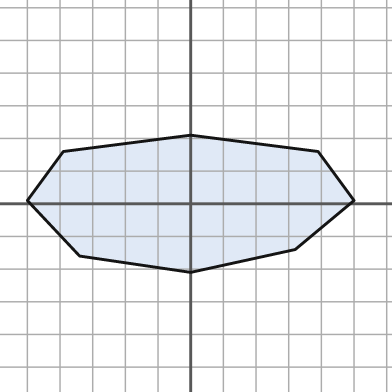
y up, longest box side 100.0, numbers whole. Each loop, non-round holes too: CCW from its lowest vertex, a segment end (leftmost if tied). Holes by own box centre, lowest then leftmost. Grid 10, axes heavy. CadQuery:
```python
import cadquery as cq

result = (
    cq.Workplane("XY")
    .moveTo(0.0, -21.0)
    .lineTo(32.0, -14.0)
    .lineTo(50.0, 1.0)
    .lineTo(39.0, 16.0)
    .lineTo(0.0, 21.0)
    .lineTo(-39.0, 16.0)
    .lineTo(-50.0, 1.0)
    .lineTo(-34.0, -16.0)
    .close()
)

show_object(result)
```